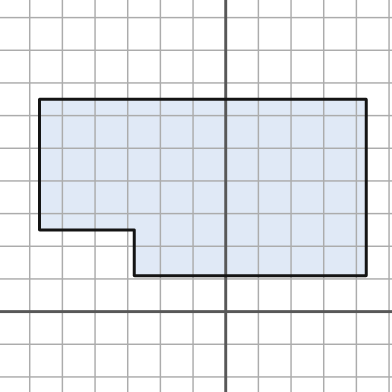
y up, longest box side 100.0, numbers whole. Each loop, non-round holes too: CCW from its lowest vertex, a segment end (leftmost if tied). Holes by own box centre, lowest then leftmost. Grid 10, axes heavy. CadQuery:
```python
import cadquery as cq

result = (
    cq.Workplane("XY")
    .moveTo(-28.0, 11.0)
    .lineTo(43.0, 11.0)
    .lineTo(43.0, 65.0)
    .lineTo(-57.0, 65.0)
    .lineTo(-57.0, 25.0)
    .lineTo(-28.0, 25.0)
    .close()
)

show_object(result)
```